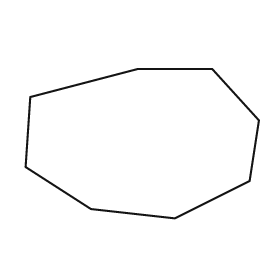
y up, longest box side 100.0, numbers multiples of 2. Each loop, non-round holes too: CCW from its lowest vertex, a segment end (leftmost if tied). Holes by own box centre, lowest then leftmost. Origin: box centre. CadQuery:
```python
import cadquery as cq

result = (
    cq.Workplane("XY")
    .moveTo(14.0, -32.0)
    .lineTo(46.0, -16.0)
    .lineTo(50.0, 10.0)
    .lineTo(30.0, 32.0)
    .lineTo(-2.0, 32.0)
    .lineTo(-48.0, 20.0)
    .lineTo(-50.0, -10.0)
    .lineTo(-22.0, -28.0)
    .close()
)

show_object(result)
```